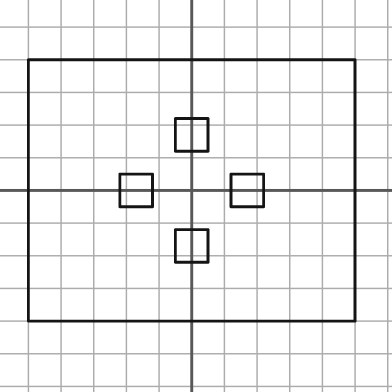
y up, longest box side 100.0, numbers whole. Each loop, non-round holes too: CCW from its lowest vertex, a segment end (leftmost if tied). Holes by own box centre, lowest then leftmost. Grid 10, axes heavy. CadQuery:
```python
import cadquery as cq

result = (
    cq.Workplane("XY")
    .moveTo(-50.0, -40.0)
    .lineTo(50.0, -40.0)
    .lineTo(50.0, 40.0)
    .lineTo(-50.0, 40.0)
    .close()
    .moveTo(-5.0, -22.0)
    .lineTo(5.0, -22.0)
    .lineTo(5.0, -12.0)
    .lineTo(-5.0, -12.0)
    .close()
    .moveTo(-22.0, -5.0)
    .lineTo(-12.0, -5.0)
    .lineTo(-12.0, 5.0)
    .lineTo(-22.0, 5.0)
    .close()
    .moveTo(12.0, -5.0)
    .lineTo(22.0, -5.0)
    .lineTo(22.0, 5.0)
    .lineTo(12.0, 5.0)
    .close()
    .moveTo(-5.0, 12.0)
    .lineTo(5.0, 12.0)
    .lineTo(5.0, 22.0)
    .lineTo(-5.0, 22.0)
    .close()
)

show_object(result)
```